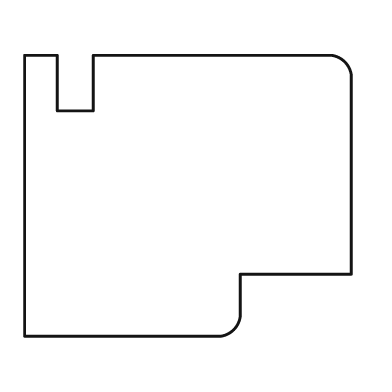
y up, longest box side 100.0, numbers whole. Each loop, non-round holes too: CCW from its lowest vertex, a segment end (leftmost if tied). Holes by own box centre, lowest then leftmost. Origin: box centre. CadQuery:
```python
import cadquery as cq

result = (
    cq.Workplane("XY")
    .moveTo(-50.0, -43.0)
    .lineTo(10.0, -43.0)
    .threePointArc((14.0, -41.0), (16.0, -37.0))
    .lineTo(16.0, -24.0)
    .lineTo(50.0, -24.0)
    .lineTo(50.0, 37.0)
    .threePointArc((48.0, 41.0), (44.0, 43.0))
    .lineTo(-29.0, 43.0)
    .lineTo(-29.0, 26.0)
    .lineTo(-40.0, 26.0)
    .lineTo(-40.0, 43.0)
    .lineTo(-50.0, 43.0)
    .close()
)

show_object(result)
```